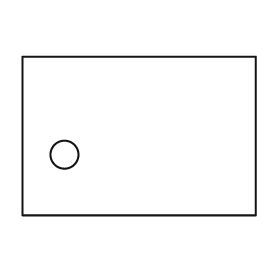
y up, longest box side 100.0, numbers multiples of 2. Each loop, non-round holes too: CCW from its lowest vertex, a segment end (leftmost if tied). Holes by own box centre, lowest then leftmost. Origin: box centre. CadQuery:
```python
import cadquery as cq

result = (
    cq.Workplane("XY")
    .moveTo(-50.0, -34.0)
    .lineTo(50.0, -34.0)
    .lineTo(50.0, 34.0)
    .lineTo(-50.0, 34.0)
    .close()
    .moveTo(-32.0, -8.0)
    .circle(6.0)
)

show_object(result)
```